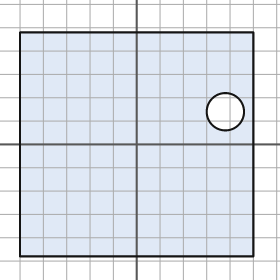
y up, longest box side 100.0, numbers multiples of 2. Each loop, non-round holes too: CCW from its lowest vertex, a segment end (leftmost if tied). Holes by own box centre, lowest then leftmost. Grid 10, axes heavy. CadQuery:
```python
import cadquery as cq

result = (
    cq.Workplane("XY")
    .moveTo(-50.0, -48.0)
    .lineTo(50.0, -48.0)
    .lineTo(50.0, 48.0)
    .lineTo(-50.0, 48.0)
    .close()
    .moveTo(38.0, 14.0)
    .circle(8.0)
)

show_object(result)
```